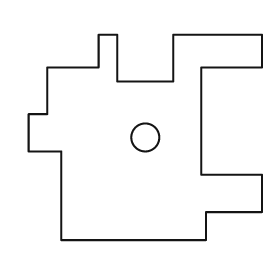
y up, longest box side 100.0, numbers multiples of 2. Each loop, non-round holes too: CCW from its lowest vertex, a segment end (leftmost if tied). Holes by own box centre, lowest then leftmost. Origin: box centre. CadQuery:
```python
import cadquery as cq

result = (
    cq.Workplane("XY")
    .moveTo(-36.0, -44.0)
    .lineTo(26.0, -44.0)
    .lineTo(26.0, -32.0)
    .lineTo(50.0, -32.0)
    .lineTo(50.0, -16.0)
    .lineTo(24.0, -16.0)
    .lineTo(24.0, 30.0)
    .lineTo(50.0, 30.0)
    .lineTo(50.0, 44.0)
    .lineTo(12.0, 44.0)
    .lineTo(12.0, 24.0)
    .lineTo(-12.0, 24.0)
    .lineTo(-12.0, 44.0)
    .lineTo(-20.0, 44.0)
    .lineTo(-20.0, 30.0)
    .lineTo(-42.0, 30.0)
    .lineTo(-42.0, 10.0)
    .lineTo(-50.0, 10.0)
    .lineTo(-50.0, -6.0)
    .lineTo(-36.0, -6.0)
    .close()
    .moveTo(0.0, 0.0)
    .circle(6.0)
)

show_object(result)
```